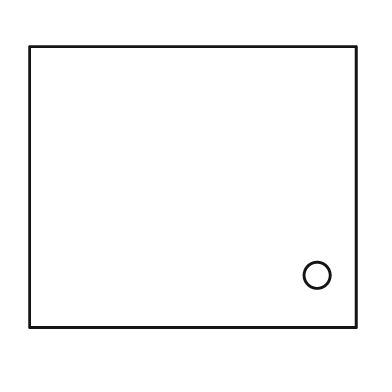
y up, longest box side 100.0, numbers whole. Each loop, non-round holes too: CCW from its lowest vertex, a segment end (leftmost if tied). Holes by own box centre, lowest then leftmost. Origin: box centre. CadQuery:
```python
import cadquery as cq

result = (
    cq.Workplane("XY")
    .moveTo(-50.0, -43.0)
    .lineTo(50.0, -43.0)
    .lineTo(50.0, 43.0)
    .lineTo(-50.0, 43.0)
    .close()
    .moveTo(38.0, -27.0)
    .circle(4.0)
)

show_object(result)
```